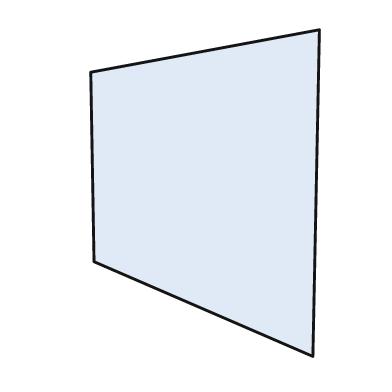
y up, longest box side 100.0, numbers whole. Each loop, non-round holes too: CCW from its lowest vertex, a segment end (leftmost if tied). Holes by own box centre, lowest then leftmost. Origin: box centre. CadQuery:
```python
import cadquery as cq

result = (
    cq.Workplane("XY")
    .moveTo(33.0, -50.0)
    .lineTo(35.0, 50.0)
    .lineTo(-35.0, 37.0)
    .lineTo(-34.0, -21.0)
    .close()
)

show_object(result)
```